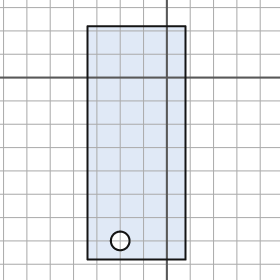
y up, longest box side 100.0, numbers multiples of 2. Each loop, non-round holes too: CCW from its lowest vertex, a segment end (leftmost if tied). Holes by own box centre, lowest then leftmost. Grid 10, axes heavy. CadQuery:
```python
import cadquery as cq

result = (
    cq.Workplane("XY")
    .moveTo(-34.0, -78.0)
    .lineTo(8.0, -78.0)
    .lineTo(8.0, 22.0)
    .lineTo(-34.0, 22.0)
    .close()
    .moveTo(-20.0, -70.0)
    .circle(4.0)
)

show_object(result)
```